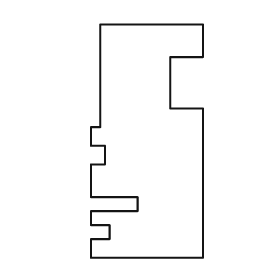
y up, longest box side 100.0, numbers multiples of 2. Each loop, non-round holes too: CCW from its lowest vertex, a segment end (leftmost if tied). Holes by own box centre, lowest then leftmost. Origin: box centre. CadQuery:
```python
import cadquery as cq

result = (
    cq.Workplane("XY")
    .moveTo(-24.0, -50.0)
    .lineTo(24.0, -50.0)
    .lineTo(24.0, 14.0)
    .lineTo(10.0, 14.0)
    .lineTo(10.0, 36.0)
    .lineTo(24.0, 36.0)
    .lineTo(24.0, 50.0)
    .lineTo(-20.0, 50.0)
    .lineTo(-20.0, 6.0)
    .lineTo(-24.0, 6.0)
    .lineTo(-24.0, -2.0)
    .lineTo(-18.0, -2.0)
    .lineTo(-18.0, -10.0)
    .lineTo(-24.0, -10.0)
    .lineTo(-24.0, -24.0)
    .lineTo(-4.0, -24.0)
    .lineTo(-4.0, -30.0)
    .lineTo(-24.0, -30.0)
    .lineTo(-24.0, -36.0)
    .lineTo(-16.0, -36.0)
    .lineTo(-16.0, -42.0)
    .lineTo(-24.0, -42.0)
    .close()
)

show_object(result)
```